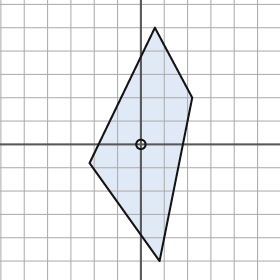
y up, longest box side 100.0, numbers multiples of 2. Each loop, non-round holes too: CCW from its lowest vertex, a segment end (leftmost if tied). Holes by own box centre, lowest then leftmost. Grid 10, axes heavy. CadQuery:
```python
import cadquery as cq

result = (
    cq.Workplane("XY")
    .moveTo(8.0, -50.0)
    .lineTo(22.0, 20.0)
    .lineTo(6.0, 50.0)
    .lineTo(-22.0, -8.0)
    .close()
    .moveTo(0.0, 0.0)
    .circle(2.0)
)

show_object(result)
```